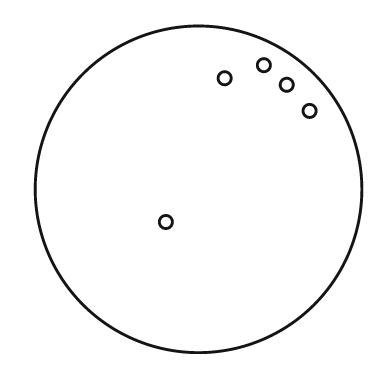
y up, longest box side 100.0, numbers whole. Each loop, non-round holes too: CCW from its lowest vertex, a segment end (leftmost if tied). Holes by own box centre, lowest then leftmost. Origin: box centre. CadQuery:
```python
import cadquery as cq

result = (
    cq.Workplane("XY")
    .moveTo(0.0, 0.0)
    .circle(50.0)
    .moveTo(-10.0, -10.0)
    .circle(2.0)
    .moveTo(34.0, 24.0)
    .circle(2.0)
    .moveTo(27.0, 32.0)
    .circle(2.0)
    .moveTo(8.0, 34.0)
    .circle(2.0)
    .moveTo(20.0, 38.0)
    .circle(2.0)
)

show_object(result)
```